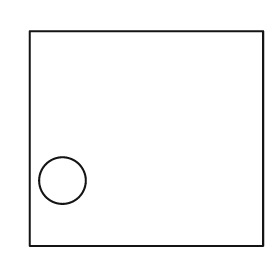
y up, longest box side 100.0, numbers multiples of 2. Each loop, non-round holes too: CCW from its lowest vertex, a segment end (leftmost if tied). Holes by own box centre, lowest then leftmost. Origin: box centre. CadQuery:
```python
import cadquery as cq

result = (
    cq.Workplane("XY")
    .moveTo(-50.0, -46.0)
    .lineTo(50.0, -46.0)
    .lineTo(50.0, 46.0)
    .lineTo(-50.0, 46.0)
    .close()
    .moveTo(-36.0, -18.0)
    .circle(10.0)
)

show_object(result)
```